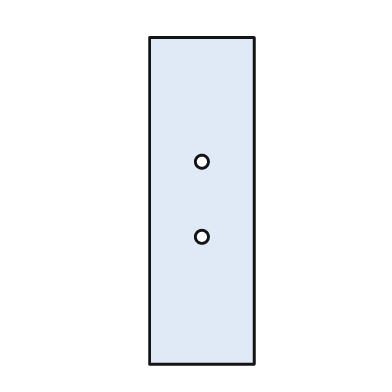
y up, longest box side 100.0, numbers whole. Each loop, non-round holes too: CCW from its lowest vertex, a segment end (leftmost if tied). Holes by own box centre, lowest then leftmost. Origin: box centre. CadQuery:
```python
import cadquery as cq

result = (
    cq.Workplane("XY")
    .moveTo(-16.0, -50.0)
    .lineTo(16.0, -50.0)
    .lineTo(16.0, 50.0)
    .lineTo(-16.0, 50.0)
    .close()
    .moveTo(0.0, -11.0)
    .circle(2.0)
    .moveTo(0.0, 12.0)
    .circle(2.0)
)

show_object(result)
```